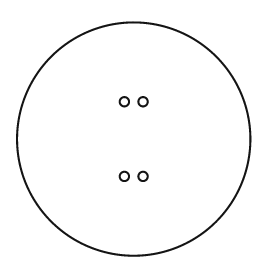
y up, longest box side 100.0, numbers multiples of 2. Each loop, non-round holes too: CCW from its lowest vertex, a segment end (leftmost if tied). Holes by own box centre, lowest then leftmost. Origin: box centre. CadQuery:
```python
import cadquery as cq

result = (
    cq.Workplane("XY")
    .moveTo(0.0, 0.0)
    .circle(50.0)
    .moveTo(-4.0, -16.0)
    .circle(2.0)
    .moveTo(4.0, -16.0)
    .circle(2.0)
    .moveTo(-4.0, 16.0)
    .circle(2.0)
    .moveTo(4.0, 16.0)
    .circle(2.0)
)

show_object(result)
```